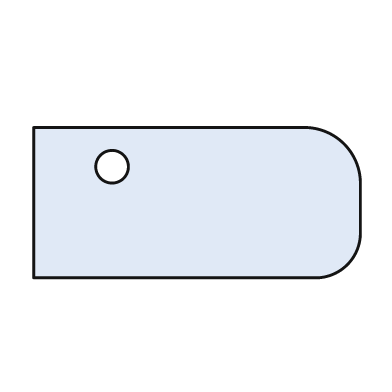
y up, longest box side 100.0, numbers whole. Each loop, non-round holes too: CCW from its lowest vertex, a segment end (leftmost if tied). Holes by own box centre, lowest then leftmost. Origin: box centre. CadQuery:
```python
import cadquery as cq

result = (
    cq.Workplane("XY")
    .moveTo(-50.0, -23.0)
    .lineTo(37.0, -23.0)
    .threePointArc((46.0, -19.0), (50.0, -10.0))
    .lineTo(50.0, 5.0)
    .threePointArc((45.0, 18.0), (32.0, 23.0))
    .lineTo(-50.0, 23.0)
    .close()
    .moveTo(-26.0, 11.0)
    .circle(5.0)
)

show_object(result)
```